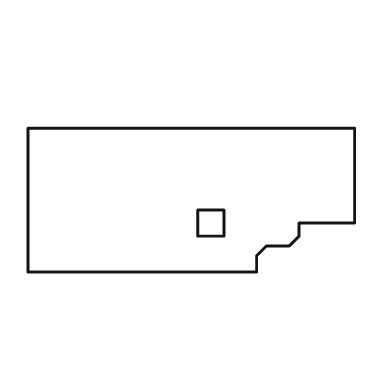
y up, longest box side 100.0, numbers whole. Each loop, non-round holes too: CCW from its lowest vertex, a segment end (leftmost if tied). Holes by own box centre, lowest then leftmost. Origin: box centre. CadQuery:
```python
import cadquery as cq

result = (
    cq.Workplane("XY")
    .moveTo(-50.0, -22.0)
    .lineTo(20.0, -22.0)
    .lineTo(20.0, -17.0)
    .lineTo(23.0, -14.0)
    .lineTo(30.0, -14.0)
    .lineTo(33.0, -11.0)
    .lineTo(33.0, -7.0)
    .lineTo(50.0, -7.0)
    .lineTo(50.0, 22.0)
    .lineTo(-50.0, 22.0)
    .close()
    .moveTo(2.0, -11.0)
    .lineTo(10.0, -11.0)
    .lineTo(10.0, -3.0)
    .lineTo(2.0, -3.0)
    .close()
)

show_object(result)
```